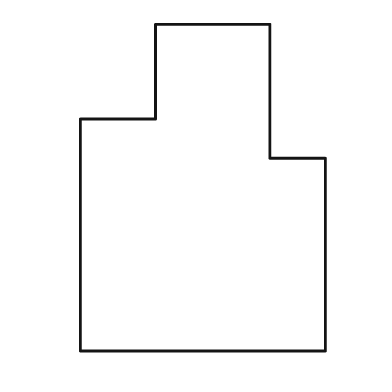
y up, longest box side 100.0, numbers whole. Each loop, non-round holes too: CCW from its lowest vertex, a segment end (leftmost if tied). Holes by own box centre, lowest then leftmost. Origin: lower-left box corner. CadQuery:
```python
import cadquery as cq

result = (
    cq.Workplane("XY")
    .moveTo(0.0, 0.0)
    .lineTo(75.0, 0.0)
    .lineTo(75.0, 59.0)
    .lineTo(58.0, 59.0)
    .lineTo(58.0, 100.0)
    .lineTo(23.0, 100.0)
    .lineTo(23.0, 71.0)
    .lineTo(0.0, 71.0)
    .close()
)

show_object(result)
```